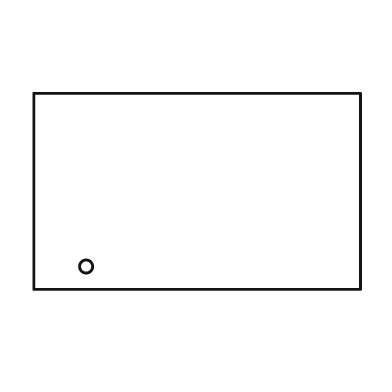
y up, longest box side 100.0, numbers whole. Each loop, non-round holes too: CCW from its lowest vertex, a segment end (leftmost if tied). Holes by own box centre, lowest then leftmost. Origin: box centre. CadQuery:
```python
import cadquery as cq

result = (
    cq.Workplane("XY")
    .moveTo(-50.0, -30.0)
    .lineTo(50.0, -30.0)
    .lineTo(50.0, 30.0)
    .lineTo(-50.0, 30.0)
    .close()
    .moveTo(-34.0, -23.0)
    .circle(2.0)
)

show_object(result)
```